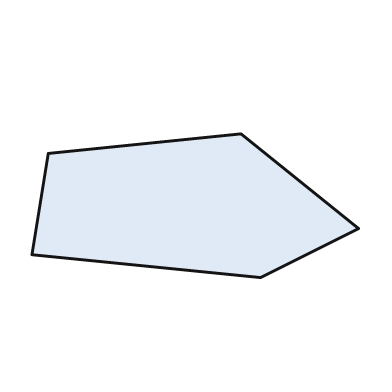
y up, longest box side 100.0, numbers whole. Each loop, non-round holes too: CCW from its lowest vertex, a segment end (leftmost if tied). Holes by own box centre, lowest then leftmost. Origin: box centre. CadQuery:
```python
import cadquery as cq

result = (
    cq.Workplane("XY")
    .moveTo(20.0, -22.0)
    .lineTo(50.0, -7.0)
    .lineTo(14.0, 22.0)
    .lineTo(-45.0, 16.0)
    .lineTo(-50.0, -15.0)
    .close()
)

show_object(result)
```